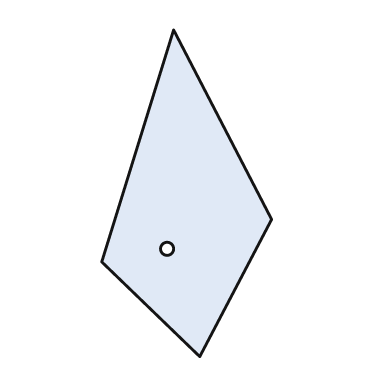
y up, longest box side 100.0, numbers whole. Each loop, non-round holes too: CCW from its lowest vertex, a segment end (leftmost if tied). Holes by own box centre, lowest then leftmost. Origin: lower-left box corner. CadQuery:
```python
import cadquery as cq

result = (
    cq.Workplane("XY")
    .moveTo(30.0, 0.0)
    .lineTo(52.0, 42.0)
    .lineTo(22.0, 100.0)
    .lineTo(0.0, 29.0)
    .close()
    .moveTo(20.0, 33.0)
    .circle(2.0)
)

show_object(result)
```